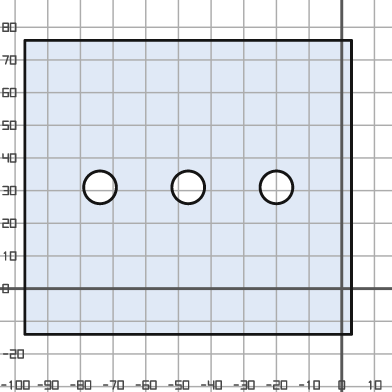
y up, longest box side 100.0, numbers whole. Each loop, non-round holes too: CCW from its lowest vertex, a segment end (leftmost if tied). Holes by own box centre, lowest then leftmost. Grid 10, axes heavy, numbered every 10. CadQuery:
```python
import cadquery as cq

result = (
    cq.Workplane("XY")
    .moveTo(-97.0, -14.0)
    .lineTo(3.0, -14.0)
    .lineTo(3.0, 76.0)
    .lineTo(-97.0, 76.0)
    .close()
    .moveTo(-74.0, 31.0)
    .circle(5.0)
    .moveTo(-47.0, 31.0)
    .circle(5.0)
    .moveTo(-20.0, 31.0)
    .circle(5.0)
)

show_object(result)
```